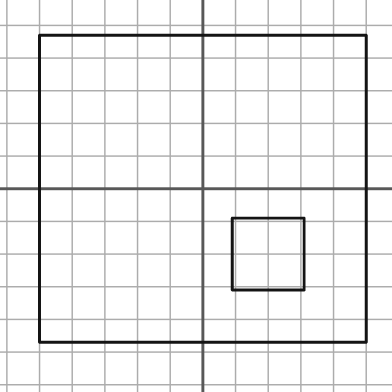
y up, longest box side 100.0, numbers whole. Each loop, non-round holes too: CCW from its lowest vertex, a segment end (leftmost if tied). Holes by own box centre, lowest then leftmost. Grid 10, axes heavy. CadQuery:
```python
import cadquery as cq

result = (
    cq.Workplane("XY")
    .moveTo(-50.0, -47.0)
    .lineTo(50.0, -47.0)
    .lineTo(50.0, 47.0)
    .lineTo(-50.0, 47.0)
    .close()
    .moveTo(9.0, -31.0)
    .lineTo(31.0, -31.0)
    .lineTo(31.0, -9.0)
    .lineTo(9.0, -9.0)
    .close()
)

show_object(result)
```